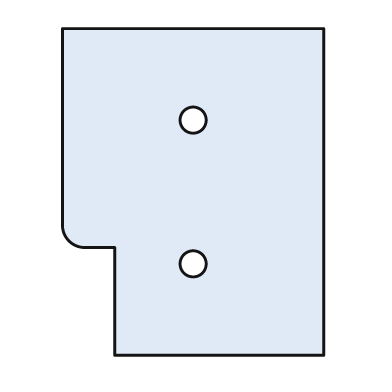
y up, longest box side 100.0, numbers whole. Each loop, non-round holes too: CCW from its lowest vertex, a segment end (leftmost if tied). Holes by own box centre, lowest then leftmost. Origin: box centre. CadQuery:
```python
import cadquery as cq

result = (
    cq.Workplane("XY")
    .moveTo(-24.0, -50.0)
    .lineTo(40.0, -50.0)
    .lineTo(40.0, 50.0)
    .lineTo(-40.0, 50.0)
    .lineTo(-40.0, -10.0)
    .threePointArc((-38.0, -15.0), (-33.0, -17.0))
    .lineTo(-24.0, -17.0)
    .close()
    .moveTo(0.0, -22.0)
    .circle(4.0)
    .moveTo(0.0, 22.0)
    .circle(4.0)
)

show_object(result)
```